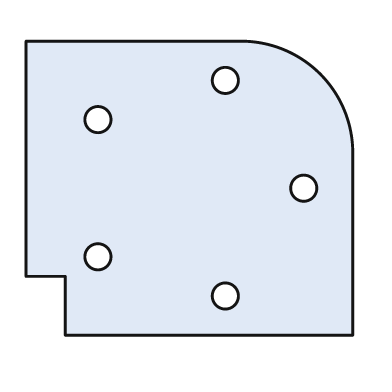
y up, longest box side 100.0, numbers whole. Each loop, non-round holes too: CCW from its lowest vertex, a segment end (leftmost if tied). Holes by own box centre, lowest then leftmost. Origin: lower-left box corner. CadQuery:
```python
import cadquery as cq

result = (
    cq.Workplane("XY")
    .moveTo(12.0, 0.0)
    .lineTo(100.0, 0.0)
    .lineTo(100.0, 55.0)
    .threePointArc((90.0, 80.0), (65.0, 90.0))
    .lineTo(0.0, 90.0)
    .lineTo(0.0, 18.0)
    .lineTo(12.0, 18.0)
    .close()
    .moveTo(61.0, 12.0)
    .circle(4.0)
    .moveTo(22.0, 24.0)
    .circle(4.0)
    .moveTo(85.0, 45.0)
    .circle(4.0)
    .moveTo(22.0, 66.0)
    .circle(4.0)
    .moveTo(61.0, 78.0)
    .circle(4.0)
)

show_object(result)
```